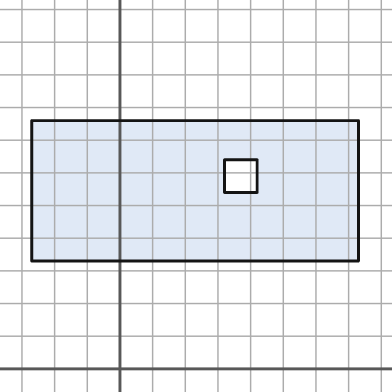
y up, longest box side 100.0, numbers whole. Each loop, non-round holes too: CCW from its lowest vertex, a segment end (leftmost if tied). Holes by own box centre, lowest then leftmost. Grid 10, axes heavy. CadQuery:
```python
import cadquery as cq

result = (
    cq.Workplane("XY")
    .moveTo(-27.0, 33.0)
    .lineTo(73.0, 33.0)
    .lineTo(73.0, 76.0)
    .lineTo(-27.0, 76.0)
    .close()
    .moveTo(32.0, 54.0)
    .lineTo(42.0, 54.0)
    .lineTo(42.0, 64.0)
    .lineTo(32.0, 64.0)
    .close()
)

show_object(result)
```